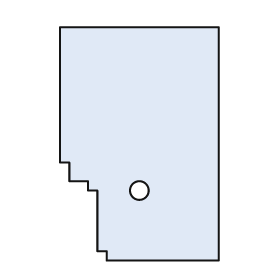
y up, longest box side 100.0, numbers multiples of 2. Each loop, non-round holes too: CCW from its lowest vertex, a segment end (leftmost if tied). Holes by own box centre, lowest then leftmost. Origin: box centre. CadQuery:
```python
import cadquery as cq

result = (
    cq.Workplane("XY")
    .moveTo(-14.0, -50.0)
    .lineTo(34.0, -50.0)
    .lineTo(34.0, 50.0)
    .lineTo(-34.0, 50.0)
    .lineTo(-34.0, -8.0)
    .lineTo(-30.0, -8.0)
    .lineTo(-30.0, -16.0)
    .lineTo(-22.0, -16.0)
    .lineTo(-22.0, -20.0)
    .lineTo(-18.0, -20.0)
    .lineTo(-18.0, -46.0)
    .lineTo(-14.0, -46.0)
    .close()
    .moveTo(0.0, -20.0)
    .circle(4.0)
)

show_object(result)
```